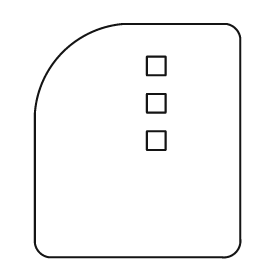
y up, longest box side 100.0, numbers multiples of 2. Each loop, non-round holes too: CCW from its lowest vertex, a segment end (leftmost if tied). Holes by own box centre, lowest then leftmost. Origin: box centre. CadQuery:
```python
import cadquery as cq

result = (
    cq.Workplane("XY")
    .moveTo(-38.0, -50.0)
    .lineTo(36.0, -50.0)
    .threePointArc((42.0, -48.0), (44.0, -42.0))
    .lineTo(44.0, 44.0)
    .threePointArc((42.0, 48.0), (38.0, 50.0))
    .lineTo(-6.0, 50.0)
    .threePointArc((-32.0, 38.0), (-44.0, 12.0))
    .lineTo(-44.0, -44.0)
    .threePointArc((-42.0, -48.0), (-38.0, -50.0))
    .close()
    .moveTo(4.0, -4.0)
    .lineTo(12.0, -4.0)
    .lineTo(12.0, 4.0)
    .lineTo(4.0, 4.0)
    .close()
    .moveTo(4.0, 12.0)
    .lineTo(12.0, 12.0)
    .lineTo(12.0, 20.0)
    .lineTo(4.0, 20.0)
    .close()
    .moveTo(4.0, 28.0)
    .lineTo(12.0, 28.0)
    .lineTo(12.0, 36.0)
    .lineTo(4.0, 36.0)
    .close()
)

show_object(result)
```